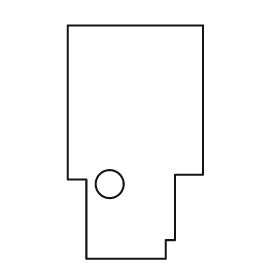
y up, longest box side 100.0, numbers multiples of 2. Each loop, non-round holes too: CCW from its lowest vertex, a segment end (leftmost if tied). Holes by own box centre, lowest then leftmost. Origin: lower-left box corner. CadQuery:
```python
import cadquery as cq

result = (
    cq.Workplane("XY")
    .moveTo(8.0, 0.0)
    .lineTo(42.0, 0.0)
    .lineTo(42.0, 8.0)
    .lineTo(46.0, 8.0)
    .lineTo(46.0, 36.0)
    .lineTo(58.0, 36.0)
    .lineTo(58.0, 100.0)
    .lineTo(0.0, 100.0)
    .lineTo(0.0, 34.0)
    .lineTo(8.0, 34.0)
    .close()
    .moveTo(18.0, 32.0)
    .circle(6.0)
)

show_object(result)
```